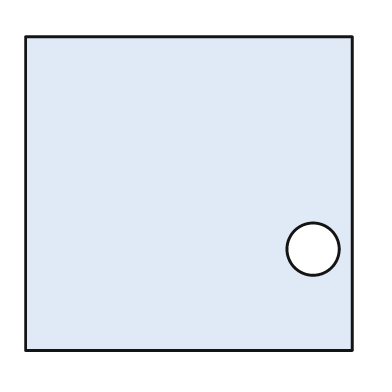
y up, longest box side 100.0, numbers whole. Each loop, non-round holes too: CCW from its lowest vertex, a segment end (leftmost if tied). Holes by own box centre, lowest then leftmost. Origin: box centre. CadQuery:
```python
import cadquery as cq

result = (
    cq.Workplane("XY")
    .moveTo(-50.0, -48.0)
    .lineTo(50.0, -48.0)
    .lineTo(50.0, 48.0)
    .lineTo(-50.0, 48.0)
    .close()
    .moveTo(38.0, -17.0)
    .circle(8.0)
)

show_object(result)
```